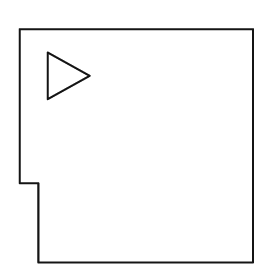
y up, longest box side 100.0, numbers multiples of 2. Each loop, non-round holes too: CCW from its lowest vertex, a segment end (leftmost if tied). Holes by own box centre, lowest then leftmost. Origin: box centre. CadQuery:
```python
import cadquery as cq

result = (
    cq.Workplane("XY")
    .moveTo(-42.0, -50.0)
    .lineTo(50.0, -50.0)
    .lineTo(50.0, 50.0)
    .lineTo(-50.0, 50.0)
    .lineTo(-50.0, -16.0)
    .lineTo(-42.0, -16.0)
    .close()
    .moveTo(-38.0, 20.0)
    .lineTo(-20.0, 30.0)
    .lineTo(-38.0, 40.0)
    .close()
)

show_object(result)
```